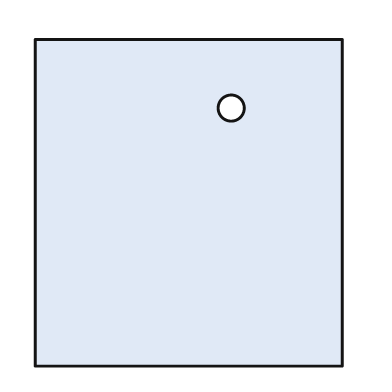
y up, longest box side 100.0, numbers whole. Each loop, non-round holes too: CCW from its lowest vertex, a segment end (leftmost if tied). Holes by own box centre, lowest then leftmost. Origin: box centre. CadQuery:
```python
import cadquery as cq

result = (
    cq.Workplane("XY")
    .moveTo(-47.0, -50.0)
    .lineTo(47.0, -50.0)
    .lineTo(47.0, 50.0)
    .lineTo(-47.0, 50.0)
    .close()
    .moveTo(13.0, 29.0)
    .circle(4.0)
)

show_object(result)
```